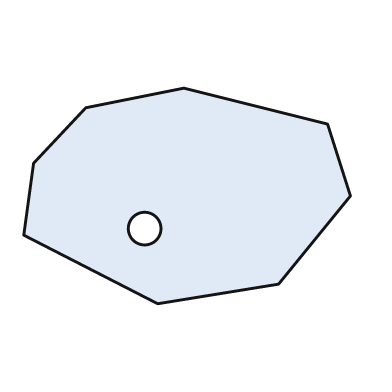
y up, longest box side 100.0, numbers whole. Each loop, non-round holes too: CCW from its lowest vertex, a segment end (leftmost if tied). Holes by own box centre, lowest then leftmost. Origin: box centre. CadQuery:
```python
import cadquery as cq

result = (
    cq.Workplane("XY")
    .moveTo(-9.0, -33.0)
    .lineTo(28.0, -27.0)
    .lineTo(50.0, 0.0)
    .lineTo(43.0, 22.0)
    .lineTo(-1.0, 33.0)
    .lineTo(-31.0, 27.0)
    .lineTo(-47.0, 10.0)
    .lineTo(-50.0, -12.0)
    .close()
    .moveTo(-13.0, -10.0)
    .circle(5.0)
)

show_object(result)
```